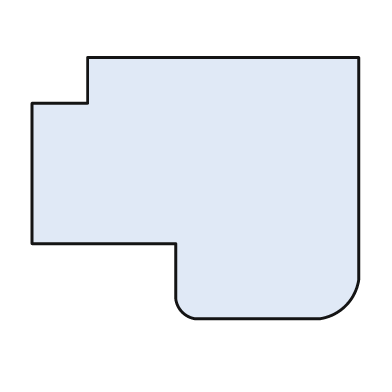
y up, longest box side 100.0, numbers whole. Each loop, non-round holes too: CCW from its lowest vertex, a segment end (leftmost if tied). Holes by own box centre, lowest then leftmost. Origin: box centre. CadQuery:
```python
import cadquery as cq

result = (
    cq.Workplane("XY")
    .moveTo(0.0, -40.0)
    .lineTo(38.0, -40.0)
    .threePointArc((46.0, -36.0), (50.0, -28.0))
    .lineTo(50.0, 40.0)
    .lineTo(-33.0, 40.0)
    .lineTo(-33.0, 26.0)
    .lineTo(-50.0, 26.0)
    .lineTo(-50.0, -17.0)
    .lineTo(-6.0, -17.0)
    .lineTo(-6.0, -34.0)
    .threePointArc((-4.0, -38.0), (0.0, -40.0))
    .close()
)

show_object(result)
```